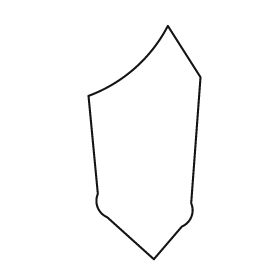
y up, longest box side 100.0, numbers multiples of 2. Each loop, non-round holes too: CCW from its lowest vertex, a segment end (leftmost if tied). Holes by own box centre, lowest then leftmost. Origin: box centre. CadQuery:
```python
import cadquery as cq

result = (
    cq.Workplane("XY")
    .moveTo(4.0, -50.0)
    .lineTo(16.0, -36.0)
    .threePointArc((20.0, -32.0), (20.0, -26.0))
    .lineTo(24.0, 28.0)
    .lineTo(10.0, 50.0)
    .threePointArc((-4.0, 32.0), (-24.0, 20.0))
    .lineTo(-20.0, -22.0)
    .threePointArc((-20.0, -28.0), (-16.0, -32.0))
    .close()
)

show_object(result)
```